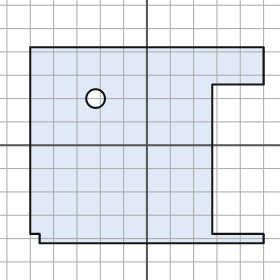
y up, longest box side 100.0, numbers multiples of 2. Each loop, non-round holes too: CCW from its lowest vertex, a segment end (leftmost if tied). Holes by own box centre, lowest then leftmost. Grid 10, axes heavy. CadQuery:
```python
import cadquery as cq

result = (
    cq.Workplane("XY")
    .moveTo(-46.0, -42.0)
    .lineTo(50.0, -42.0)
    .lineTo(50.0, -38.0)
    .lineTo(28.0, -38.0)
    .lineTo(28.0, 26.0)
    .lineTo(50.0, 26.0)
    .lineTo(50.0, 42.0)
    .lineTo(-50.0, 42.0)
    .lineTo(-50.0, -38.0)
    .lineTo(-46.0, -38.0)
    .close()
    .moveTo(-22.0, 20.0)
    .circle(4.0)
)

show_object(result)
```